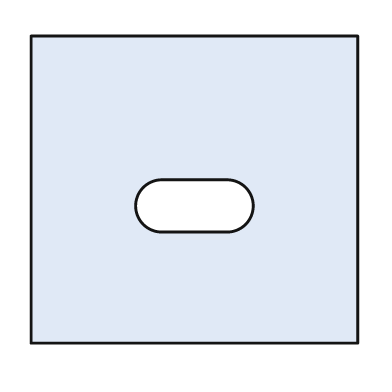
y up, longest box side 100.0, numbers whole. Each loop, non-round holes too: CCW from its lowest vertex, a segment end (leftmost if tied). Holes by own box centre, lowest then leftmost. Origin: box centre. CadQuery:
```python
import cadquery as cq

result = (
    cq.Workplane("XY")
    .moveTo(-50.0, -47.0)
    .lineTo(50.0, -47.0)
    .lineTo(50.0, 47.0)
    .lineTo(-50.0, 47.0)
    .close()
    .moveTo(-10.0, -13.0)
    .lineTo(10.0, -13.0)
    .threePointArc((18.0, -5.0), (10.0, 3.0))
    .lineTo(-10.0, 3.0)
    .threePointArc((-18.0, -5.0), (-10.0, -13.0))
    .close()
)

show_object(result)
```